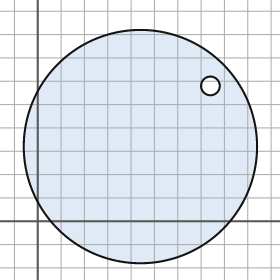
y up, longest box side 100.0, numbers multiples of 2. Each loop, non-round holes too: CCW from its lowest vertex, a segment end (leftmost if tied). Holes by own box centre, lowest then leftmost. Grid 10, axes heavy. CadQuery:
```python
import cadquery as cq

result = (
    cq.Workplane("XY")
    .moveTo(44.0, 32.0)
    .circle(50.0)
    .moveTo(74.0, 58.0)
    .circle(4.0)
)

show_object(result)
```